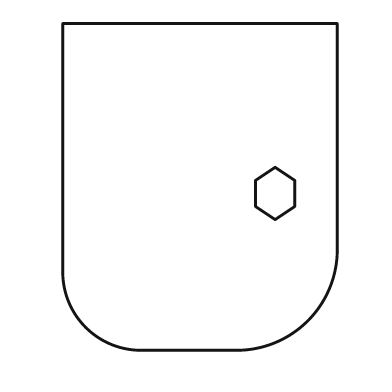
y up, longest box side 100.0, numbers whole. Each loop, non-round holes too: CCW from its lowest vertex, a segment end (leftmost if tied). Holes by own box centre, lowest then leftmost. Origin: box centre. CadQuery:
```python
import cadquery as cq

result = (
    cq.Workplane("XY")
    .moveTo(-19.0, -50.0)
    .lineTo(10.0, -50.0)
    .threePointArc((33.0, -41.0), (42.0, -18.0))
    .lineTo(42.0, 50.0)
    .lineTo(-42.0, 50.0)
    .lineTo(-42.0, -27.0)
    .threePointArc((-35.0, -43.0), (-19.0, -50.0))
    .close()
    .moveTo(23.0, -10.0)
    .lineTo(29.0, -6.0)
    .lineTo(29.0, 2.0)
    .lineTo(23.0, 6.0)
    .lineTo(17.0, 2.0)
    .lineTo(17.0, -6.0)
    .close()
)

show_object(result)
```